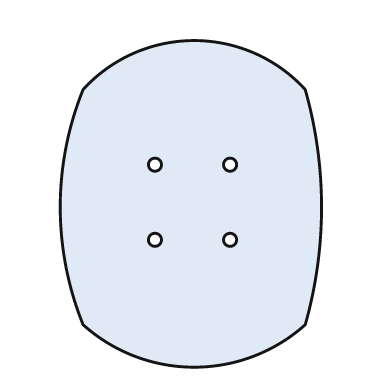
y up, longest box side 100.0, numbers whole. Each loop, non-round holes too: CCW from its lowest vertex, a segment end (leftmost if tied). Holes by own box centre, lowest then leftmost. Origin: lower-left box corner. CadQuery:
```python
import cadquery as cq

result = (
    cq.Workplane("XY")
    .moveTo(7.0, 13.0)
    .threePointArc((41.0, 0.0), (75.0, 13.0))
    .threePointArc((80.0, 49.0), (75.0, 85.0))
    .threePointArc((41.0, 100.0), (7.0, 85.0))
    .threePointArc((0.0, 49.0), (7.0, 13.0))
    .close()
    .moveTo(29.0, 39.0)
    .circle(2.0)
    .moveTo(52.0, 39.0)
    .circle(2.0)
    .moveTo(29.0, 62.0)
    .circle(2.0)
    .moveTo(52.0, 62.0)
    .circle(2.0)
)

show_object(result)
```